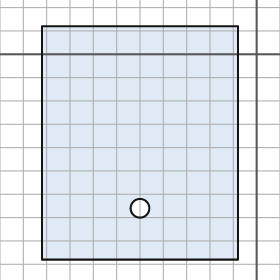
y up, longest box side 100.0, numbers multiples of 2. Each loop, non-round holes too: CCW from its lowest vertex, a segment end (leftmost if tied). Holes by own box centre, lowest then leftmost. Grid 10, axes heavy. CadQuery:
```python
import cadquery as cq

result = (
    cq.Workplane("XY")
    .moveTo(-92.0, -88.0)
    .lineTo(-8.0, -88.0)
    .lineTo(-8.0, 12.0)
    .lineTo(-92.0, 12.0)
    .close()
    .moveTo(-50.0, -66.0)
    .circle(4.0)
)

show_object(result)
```